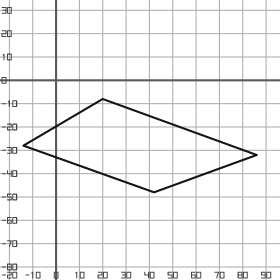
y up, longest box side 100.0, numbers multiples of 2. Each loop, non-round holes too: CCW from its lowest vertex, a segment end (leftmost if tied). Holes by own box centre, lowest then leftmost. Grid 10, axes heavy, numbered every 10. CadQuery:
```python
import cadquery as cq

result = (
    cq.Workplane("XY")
    .moveTo(42.0, -48.0)
    .lineTo(86.0, -32.0)
    .lineTo(20.0, -8.0)
    .lineTo(-14.0, -28.0)
    .close()
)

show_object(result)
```